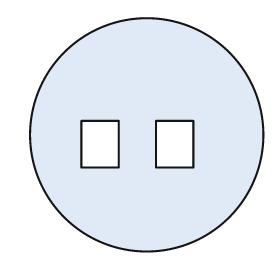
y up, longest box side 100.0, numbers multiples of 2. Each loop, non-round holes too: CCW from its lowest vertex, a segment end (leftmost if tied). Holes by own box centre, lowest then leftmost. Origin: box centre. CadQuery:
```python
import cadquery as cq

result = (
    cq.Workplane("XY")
    .moveTo(0.0, 0.0)
    .circle(50.0)
    .moveTo(-28.0, -14.0)
    .lineTo(-12.0, -14.0)
    .lineTo(-12.0, 6.0)
    .lineTo(-28.0, 6.0)
    .close()
    .moveTo(4.0, -14.0)
    .lineTo(20.0, -14.0)
    .lineTo(20.0, 6.0)
    .lineTo(4.0, 6.0)
    .close()
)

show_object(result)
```